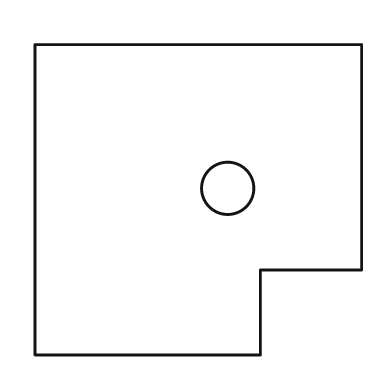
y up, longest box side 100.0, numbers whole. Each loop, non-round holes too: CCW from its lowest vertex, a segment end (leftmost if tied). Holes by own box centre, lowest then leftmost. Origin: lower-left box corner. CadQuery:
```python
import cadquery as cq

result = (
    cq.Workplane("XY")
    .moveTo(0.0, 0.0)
    .lineTo(69.0, 0.0)
    .lineTo(69.0, 26.0)
    .lineTo(100.0, 26.0)
    .lineTo(100.0, 95.0)
    .lineTo(0.0, 95.0)
    .close()
    .moveTo(59.0, 51.0)
    .circle(8.0)
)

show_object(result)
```